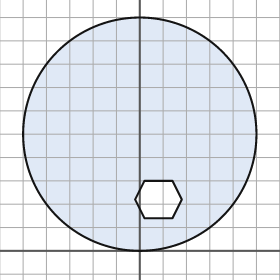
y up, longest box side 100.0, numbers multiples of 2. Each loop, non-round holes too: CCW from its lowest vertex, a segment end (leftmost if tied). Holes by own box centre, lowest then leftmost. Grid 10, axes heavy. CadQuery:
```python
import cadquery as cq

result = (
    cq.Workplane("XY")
    .moveTo(0.0, 50.0)
    .circle(50.0)
    .moveTo(2.0, 14.0)
    .lineTo(14.0, 14.0)
    .lineTo(18.0, 22.0)
    .lineTo(14.0, 30.0)
    .lineTo(2.0, 30.0)
    .lineTo(-2.0, 22.0)
    .close()
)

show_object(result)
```